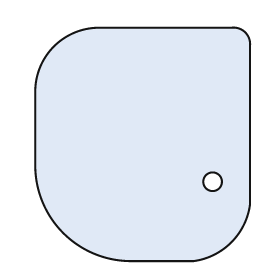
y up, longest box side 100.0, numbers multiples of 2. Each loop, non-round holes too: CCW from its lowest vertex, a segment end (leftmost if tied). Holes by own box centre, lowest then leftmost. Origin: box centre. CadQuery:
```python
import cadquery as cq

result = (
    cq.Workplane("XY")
    .moveTo(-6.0, -50.0)
    .lineTo(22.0, -50.0)
    .threePointArc((38.0, -42.0), (46.0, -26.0))
    .lineTo(46.0, 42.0)
    .threePointArc((44.0, 48.0), (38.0, 50.0))
    .lineTo(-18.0, 50.0)
    .threePointArc((-38.0, 42.0), (-46.0, 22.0))
    .lineTo(-46.0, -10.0)
    .threePointArc((-34.0, -38.0), (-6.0, -50.0))
    .close()
    .moveTo(30.0, -16.0)
    .circle(4.0)
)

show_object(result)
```